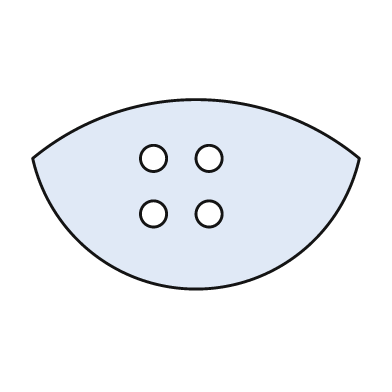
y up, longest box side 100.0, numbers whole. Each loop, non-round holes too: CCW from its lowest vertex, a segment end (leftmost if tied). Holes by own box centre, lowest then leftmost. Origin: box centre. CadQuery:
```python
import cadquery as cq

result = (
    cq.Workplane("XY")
    .moveTo(-50.0, 11.0)
    .threePointArc((0.0, -29.0), (50.0, 11.0))
    .threePointArc((0.0, 29.0), (-50.0, 11.0))
    .close()
    .moveTo(-13.0, -6.0)
    .circle(4.0)
    .moveTo(4.0, -6.0)
    .circle(4.0)
    .moveTo(-13.0, 11.0)
    .circle(4.0)
    .moveTo(4.0, 11.0)
    .circle(4.0)
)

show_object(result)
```